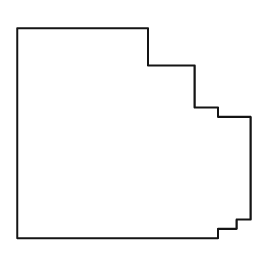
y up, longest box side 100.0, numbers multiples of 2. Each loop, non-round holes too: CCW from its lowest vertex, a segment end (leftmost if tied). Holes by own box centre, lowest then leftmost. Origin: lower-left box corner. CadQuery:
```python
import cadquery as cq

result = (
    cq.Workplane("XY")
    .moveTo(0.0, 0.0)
    .lineTo(86.0, 0.0)
    .lineTo(86.0, 4.0)
    .lineTo(94.0, 4.0)
    .lineTo(94.0, 8.0)
    .lineTo(100.0, 8.0)
    .lineTo(100.0, 52.0)
    .lineTo(86.0, 52.0)
    .lineTo(86.0, 56.0)
    .lineTo(76.0, 56.0)
    .lineTo(76.0, 74.0)
    .lineTo(56.0, 74.0)
    .lineTo(56.0, 90.0)
    .lineTo(0.0, 90.0)
    .close()
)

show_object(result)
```